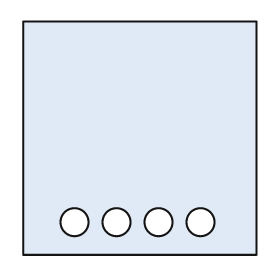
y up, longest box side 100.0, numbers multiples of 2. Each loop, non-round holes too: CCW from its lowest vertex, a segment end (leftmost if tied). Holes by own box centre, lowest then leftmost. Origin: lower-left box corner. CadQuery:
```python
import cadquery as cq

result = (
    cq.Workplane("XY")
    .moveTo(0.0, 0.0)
    .lineTo(100.0, 0.0)
    .lineTo(100.0, 100.0)
    .lineTo(0.0, 100.0)
    .close()
    .moveTo(22.0, 14.0)
    .circle(6.0)
    .moveTo(40.0, 14.0)
    .circle(6.0)
    .moveTo(58.0, 14.0)
    .circle(6.0)
    .moveTo(76.0, 14.0)
    .circle(6.0)
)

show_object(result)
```